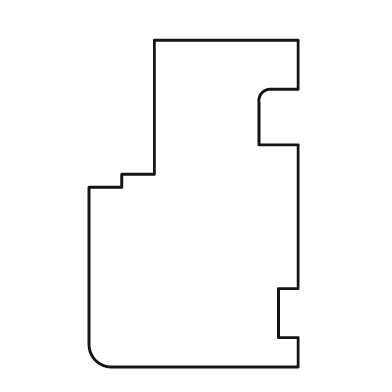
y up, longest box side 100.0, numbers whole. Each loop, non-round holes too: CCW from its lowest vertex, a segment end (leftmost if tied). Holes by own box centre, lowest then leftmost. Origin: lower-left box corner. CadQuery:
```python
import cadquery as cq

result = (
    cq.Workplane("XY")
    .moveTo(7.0, 0.0)
    .lineTo(64.0, 0.0)
    .lineTo(64.0, 9.0)
    .lineTo(58.0, 9.0)
    .lineTo(58.0, 24.0)
    .lineTo(64.0, 24.0)
    .lineTo(64.0, 68.0)
    .lineTo(52.0, 68.0)
    .lineTo(52.0, 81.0)
    .threePointArc((53.0, 84.0), (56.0, 85.0))
    .lineTo(64.0, 85.0)
    .lineTo(64.0, 100.0)
    .lineTo(20.0, 100.0)
    .lineTo(20.0, 59.0)
    .lineTo(10.0, 59.0)
    .lineTo(10.0, 55.0)
    .lineTo(0.0, 55.0)
    .lineTo(0.0, 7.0)
    .threePointArc((2.0, 2.0), (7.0, 0.0))
    .close()
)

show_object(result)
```